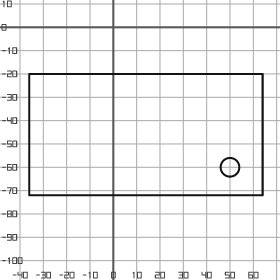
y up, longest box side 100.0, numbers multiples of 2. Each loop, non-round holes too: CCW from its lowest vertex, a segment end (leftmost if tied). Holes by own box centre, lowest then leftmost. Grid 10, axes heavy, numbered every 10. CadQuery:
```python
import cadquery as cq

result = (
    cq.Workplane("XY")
    .moveTo(-36.0, -72.0)
    .lineTo(64.0, -72.0)
    .lineTo(64.0, -20.0)
    .lineTo(-36.0, -20.0)
    .close()
    .moveTo(50.0, -60.0)
    .circle(4.0)
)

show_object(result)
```